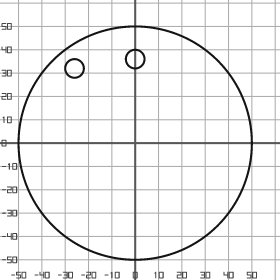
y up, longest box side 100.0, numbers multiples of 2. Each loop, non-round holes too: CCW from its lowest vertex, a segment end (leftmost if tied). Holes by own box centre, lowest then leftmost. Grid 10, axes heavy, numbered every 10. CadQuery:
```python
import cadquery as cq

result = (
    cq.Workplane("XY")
    .moveTo(0.0, 0.0)
    .circle(50.0)
    .moveTo(-26.0, 32.0)
    .circle(4.0)
    .moveTo(0.0, 36.0)
    .circle(4.0)
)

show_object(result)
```